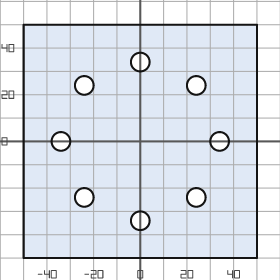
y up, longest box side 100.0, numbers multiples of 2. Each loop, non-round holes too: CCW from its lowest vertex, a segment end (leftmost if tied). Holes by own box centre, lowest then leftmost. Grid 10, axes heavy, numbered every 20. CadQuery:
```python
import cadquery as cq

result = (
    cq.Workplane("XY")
    .moveTo(-50.0, -50.0)
    .lineTo(50.0, -50.0)
    .lineTo(50.0, 50.0)
    .lineTo(-50.0, 50.0)
    .close()
    .moveTo(0.0, -34.0)
    .circle(4.0)
    .moveTo(-24.0, -24.0)
    .circle(4.0)
    .moveTo(24.0, -24.0)
    .circle(4.0)
    .moveTo(-34.0, 0.0)
    .circle(4.0)
    .moveTo(34.0, 0.0)
    .circle(4.0)
    .moveTo(-24.0, 24.0)
    .circle(4.0)
    .moveTo(24.0, 24.0)
    .circle(4.0)
    .moveTo(0.0, 34.0)
    .circle(4.0)
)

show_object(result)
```